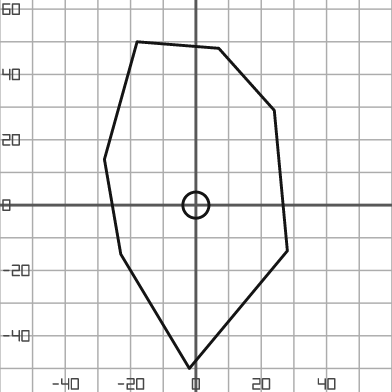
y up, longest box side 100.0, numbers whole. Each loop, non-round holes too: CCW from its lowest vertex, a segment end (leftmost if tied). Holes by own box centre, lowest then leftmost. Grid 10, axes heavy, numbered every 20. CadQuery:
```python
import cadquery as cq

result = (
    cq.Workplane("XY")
    .moveTo(-2.0, -50.0)
    .lineTo(28.0, -14.0)
    .lineTo(24.0, 29.0)
    .lineTo(7.0, 48.0)
    .lineTo(-18.0, 50.0)
    .lineTo(-28.0, 14.0)
    .lineTo(-23.0, -15.0)
    .close()
    .moveTo(0.0, 0.0)
    .circle(4.0)
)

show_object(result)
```